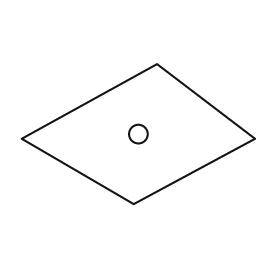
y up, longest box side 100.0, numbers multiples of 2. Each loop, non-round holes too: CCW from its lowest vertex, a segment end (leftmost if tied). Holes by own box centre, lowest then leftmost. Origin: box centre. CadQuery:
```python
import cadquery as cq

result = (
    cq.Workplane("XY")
    .moveTo(-2.0, -30.0)
    .lineTo(50.0, -2.0)
    .lineTo(8.0, 30.0)
    .lineTo(-50.0, -2.0)
    .close()
    .moveTo(0.0, 0.0)
    .circle(4.0)
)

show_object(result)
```